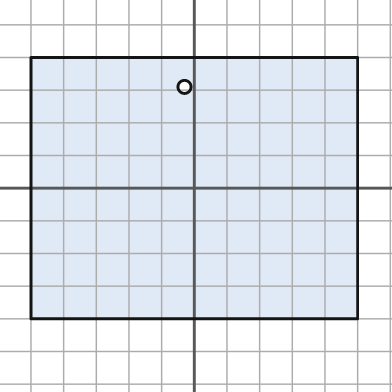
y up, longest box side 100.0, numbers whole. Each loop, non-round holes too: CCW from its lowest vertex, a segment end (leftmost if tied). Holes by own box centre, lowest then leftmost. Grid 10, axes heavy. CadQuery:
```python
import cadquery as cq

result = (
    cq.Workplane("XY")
    .moveTo(-50.0, -40.0)
    .lineTo(50.0, -40.0)
    .lineTo(50.0, 40.0)
    .lineTo(-50.0, 40.0)
    .close()
    .moveTo(-3.0, 31.0)
    .circle(2.0)
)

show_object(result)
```